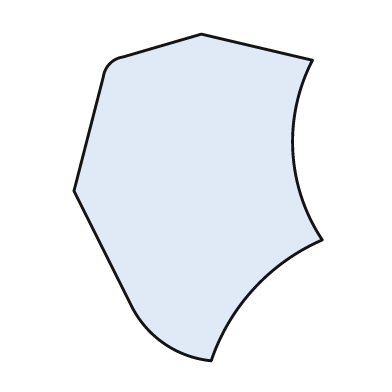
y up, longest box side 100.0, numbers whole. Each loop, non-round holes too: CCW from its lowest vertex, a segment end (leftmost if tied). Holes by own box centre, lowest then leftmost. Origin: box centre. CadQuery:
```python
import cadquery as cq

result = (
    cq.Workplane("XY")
    .moveTo(4.0, -50.0)
    .threePointArc((17.0, -28.0), (38.0, -13.0))
    .threePointArc((29.0, 14.0), (35.0, 42.0))
    .lineTo(1.0, 50.0)
    .lineTo(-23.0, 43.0)
    .threePointArc((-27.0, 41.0), (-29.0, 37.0))
    .lineTo(-38.0, 2.0)
    .lineTo(-20.0, -34.0)
    .threePointArc((-10.0, -45.0), (4.0, -50.0))
    .close()
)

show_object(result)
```